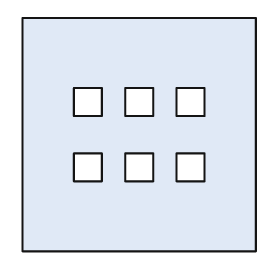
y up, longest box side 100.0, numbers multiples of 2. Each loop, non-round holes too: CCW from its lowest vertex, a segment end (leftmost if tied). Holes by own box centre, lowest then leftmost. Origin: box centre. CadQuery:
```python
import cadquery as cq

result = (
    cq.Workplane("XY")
    .moveTo(-50.0, -50.0)
    .lineTo(50.0, -50.0)
    .lineTo(50.0, 50.0)
    .lineTo(-50.0, 50.0)
    .close()
    .moveTo(-28.0, -20.0)
    .lineTo(-16.0, -20.0)
    .lineTo(-16.0, -8.0)
    .lineTo(-28.0, -8.0)
    .close()
    .moveTo(-6.0, -20.0)
    .lineTo(6.0, -20.0)
    .lineTo(6.0, -8.0)
    .lineTo(-6.0, -8.0)
    .close()
    .moveTo(16.0, -20.0)
    .lineTo(28.0, -20.0)
    .lineTo(28.0, -8.0)
    .lineTo(16.0, -8.0)
    .close()
    .moveTo(-28.0, 8.0)
    .lineTo(-16.0, 8.0)
    .lineTo(-16.0, 20.0)
    .lineTo(-28.0, 20.0)
    .close()
    .moveTo(-6.0, 8.0)
    .lineTo(6.0, 8.0)
    .lineTo(6.0, 20.0)
    .lineTo(-6.0, 20.0)
    .close()
    .moveTo(16.0, 8.0)
    .lineTo(28.0, 8.0)
    .lineTo(28.0, 20.0)
    .lineTo(16.0, 20.0)
    .close()
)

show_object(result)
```